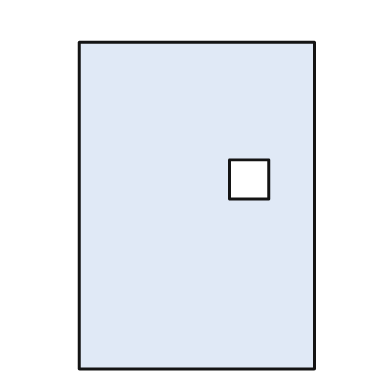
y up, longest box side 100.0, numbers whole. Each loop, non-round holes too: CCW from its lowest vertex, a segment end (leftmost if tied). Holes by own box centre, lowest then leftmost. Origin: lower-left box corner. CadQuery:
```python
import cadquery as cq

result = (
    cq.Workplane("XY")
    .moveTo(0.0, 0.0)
    .lineTo(72.0, 0.0)
    .lineTo(72.0, 100.0)
    .lineTo(0.0, 100.0)
    .close()
    .moveTo(46.0, 52.0)
    .lineTo(58.0, 52.0)
    .lineTo(58.0, 64.0)
    .lineTo(46.0, 64.0)
    .close()
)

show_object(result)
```